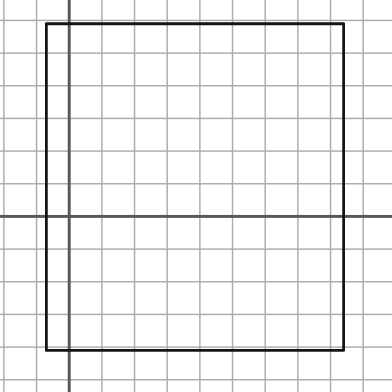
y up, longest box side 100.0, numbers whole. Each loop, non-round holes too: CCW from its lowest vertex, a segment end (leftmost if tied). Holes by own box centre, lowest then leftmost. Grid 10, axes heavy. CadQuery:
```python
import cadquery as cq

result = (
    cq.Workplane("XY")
    .moveTo(-7.0, -41.0)
    .lineTo(84.0, -41.0)
    .lineTo(84.0, 59.0)
    .lineTo(-7.0, 59.0)
    .close()
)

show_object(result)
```